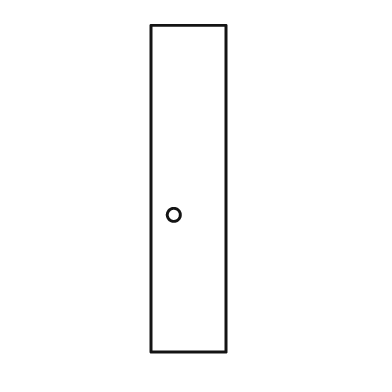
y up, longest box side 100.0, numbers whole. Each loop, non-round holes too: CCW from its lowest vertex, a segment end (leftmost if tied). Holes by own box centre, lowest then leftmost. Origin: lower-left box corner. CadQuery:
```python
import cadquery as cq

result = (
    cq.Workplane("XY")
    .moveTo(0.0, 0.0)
    .lineTo(23.0, 0.0)
    .lineTo(23.0, 100.0)
    .lineTo(0.0, 100.0)
    .close()
    .moveTo(7.0, 42.0)
    .circle(2.0)
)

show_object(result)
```